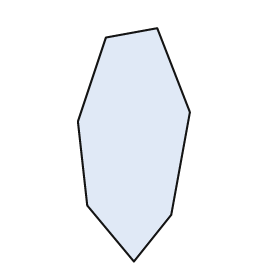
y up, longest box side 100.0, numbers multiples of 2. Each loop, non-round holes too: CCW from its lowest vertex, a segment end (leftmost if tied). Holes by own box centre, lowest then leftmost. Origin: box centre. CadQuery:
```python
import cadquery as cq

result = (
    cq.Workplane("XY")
    .moveTo(0.0, -50.0)
    .lineTo(16.0, -30.0)
    .lineTo(24.0, 14.0)
    .lineTo(10.0, 50.0)
    .lineTo(-12.0, 46.0)
    .lineTo(-24.0, 10.0)
    .lineTo(-20.0, -26.0)
    .close()
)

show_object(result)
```